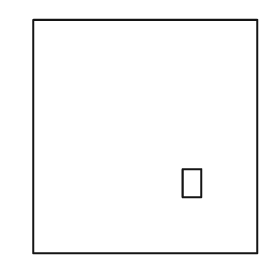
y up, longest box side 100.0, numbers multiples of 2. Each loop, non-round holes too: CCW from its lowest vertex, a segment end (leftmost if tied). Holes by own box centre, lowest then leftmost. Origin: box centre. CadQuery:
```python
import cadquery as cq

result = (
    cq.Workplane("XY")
    .moveTo(-48.0, -50.0)
    .lineTo(48.0, -50.0)
    .lineTo(48.0, 50.0)
    .lineTo(-48.0, 50.0)
    .close()
    .moveTo(16.0, -26.0)
    .lineTo(24.0, -26.0)
    .lineTo(24.0, -14.0)
    .lineTo(16.0, -14.0)
    .close()
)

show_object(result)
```